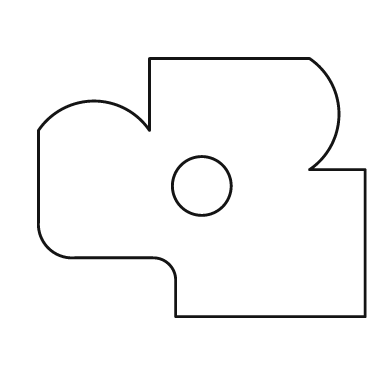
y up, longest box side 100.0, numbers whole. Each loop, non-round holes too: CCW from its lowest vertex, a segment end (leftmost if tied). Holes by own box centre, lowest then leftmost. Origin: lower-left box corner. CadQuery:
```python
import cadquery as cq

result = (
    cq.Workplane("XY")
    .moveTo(42.0, 0.0)
    .lineTo(100.0, 0.0)
    .lineTo(100.0, 45.0)
    .lineTo(83.0, 45.0)
    .threePointArc((92.0, 62.0), (83.0, 79.0))
    .lineTo(34.0, 79.0)
    .lineTo(34.0, 57.0)
    .threePointArc((17.0, 66.0), (0.0, 57.0))
    .lineTo(0.0, 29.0)
    .threePointArc((3.0, 21.0), (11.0, 18.0))
    .lineTo(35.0, 18.0)
    .threePointArc((40.0, 16.0), (42.0, 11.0))
    .close()
    .moveTo(50.0, 40.0)
    .circle(9.0)
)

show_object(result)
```